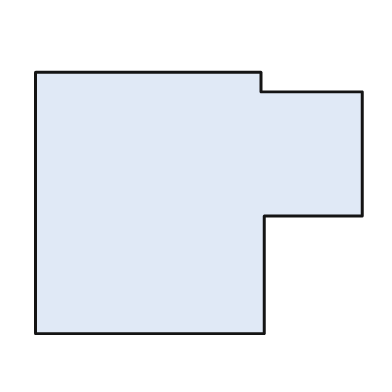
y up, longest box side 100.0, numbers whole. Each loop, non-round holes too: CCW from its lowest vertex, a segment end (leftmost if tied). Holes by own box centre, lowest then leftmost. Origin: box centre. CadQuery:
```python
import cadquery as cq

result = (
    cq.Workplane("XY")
    .moveTo(-50.0, -40.0)
    .lineTo(20.0, -40.0)
    .lineTo(20.0, -4.0)
    .lineTo(50.0, -4.0)
    .lineTo(50.0, 34.0)
    .lineTo(19.0, 34.0)
    .lineTo(19.0, 40.0)
    .lineTo(-50.0, 40.0)
    .close()
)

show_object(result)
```